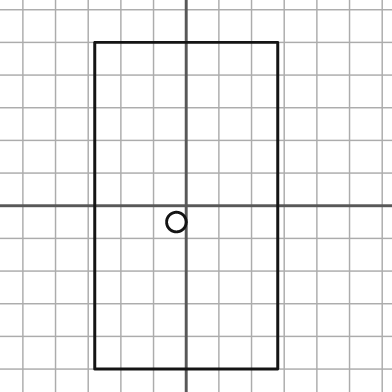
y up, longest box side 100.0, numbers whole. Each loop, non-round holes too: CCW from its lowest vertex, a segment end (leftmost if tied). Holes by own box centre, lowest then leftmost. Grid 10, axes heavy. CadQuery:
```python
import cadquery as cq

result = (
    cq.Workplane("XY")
    .moveTo(-28.0, -50.0)
    .lineTo(28.0, -50.0)
    .lineTo(28.0, 50.0)
    .lineTo(-28.0, 50.0)
    .close()
    .moveTo(-3.0, -5.0)
    .circle(3.0)
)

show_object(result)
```